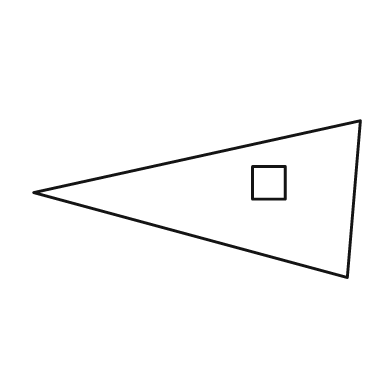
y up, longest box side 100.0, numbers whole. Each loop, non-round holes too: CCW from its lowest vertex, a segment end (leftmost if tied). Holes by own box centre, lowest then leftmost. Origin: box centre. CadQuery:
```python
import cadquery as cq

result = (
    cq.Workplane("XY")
    .moveTo(46.0, -24.0)
    .lineTo(50.0, 24.0)
    .lineTo(-50.0, 2.0)
    .close()
    .moveTo(17.0, 0.0)
    .lineTo(27.0, 0.0)
    .lineTo(27.0, 10.0)
    .lineTo(17.0, 10.0)
    .close()
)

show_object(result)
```